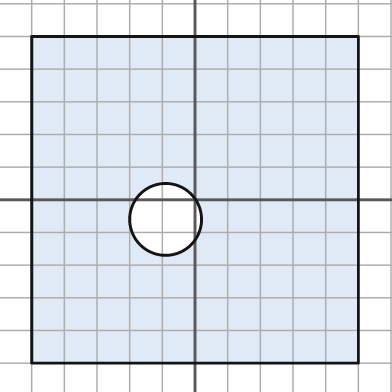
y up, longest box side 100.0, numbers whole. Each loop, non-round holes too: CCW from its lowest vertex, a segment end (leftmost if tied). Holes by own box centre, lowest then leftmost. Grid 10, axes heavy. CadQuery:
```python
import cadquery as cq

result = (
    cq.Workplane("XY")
    .moveTo(-50.0, -50.0)
    .lineTo(50.0, -50.0)
    .lineTo(50.0, 50.0)
    .lineTo(-50.0, 50.0)
    .close()
    .moveTo(-9.0, -6.0)
    .circle(11.0)
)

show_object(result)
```